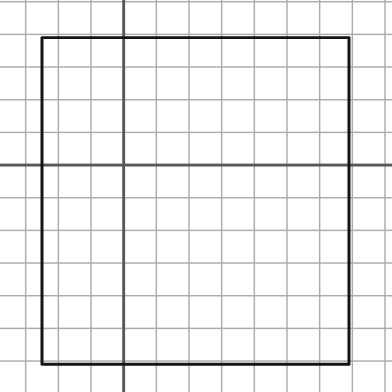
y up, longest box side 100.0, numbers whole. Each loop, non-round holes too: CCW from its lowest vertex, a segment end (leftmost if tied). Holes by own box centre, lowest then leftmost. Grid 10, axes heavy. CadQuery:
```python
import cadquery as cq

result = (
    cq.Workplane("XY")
    .moveTo(-25.0, -61.0)
    .lineTo(69.0, -61.0)
    .lineTo(69.0, 39.0)
    .lineTo(-25.0, 39.0)
    .close()
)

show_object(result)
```